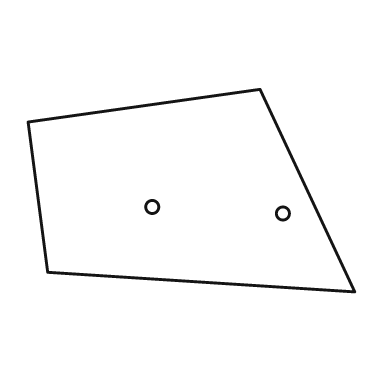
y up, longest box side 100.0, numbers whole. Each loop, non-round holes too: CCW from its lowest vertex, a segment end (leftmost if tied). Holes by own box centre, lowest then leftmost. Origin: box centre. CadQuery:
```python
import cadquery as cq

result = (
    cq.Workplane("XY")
    .moveTo(50.0, -31.0)
    .lineTo(21.0, 31.0)
    .lineTo(-50.0, 21.0)
    .lineTo(-44.0, -25.0)
    .close()
    .moveTo(28.0, -7.0)
    .circle(2.0)
    .moveTo(-12.0, -5.0)
    .circle(2.0)
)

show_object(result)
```